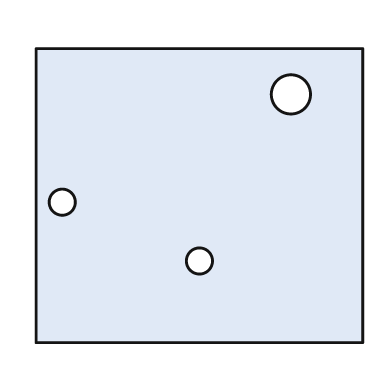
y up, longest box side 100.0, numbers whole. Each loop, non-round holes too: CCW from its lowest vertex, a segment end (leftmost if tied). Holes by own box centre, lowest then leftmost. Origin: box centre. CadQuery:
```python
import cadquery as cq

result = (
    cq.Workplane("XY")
    .moveTo(-50.0, -45.0)
    .lineTo(50.0, -45.0)
    .lineTo(50.0, 45.0)
    .lineTo(-50.0, 45.0)
    .close()
    .moveTo(0.0, -20.0)
    .circle(4.0)
    .moveTo(-42.0, -2.0)
    .circle(4.0)
    .moveTo(28.0, 31.0)
    .circle(6.0)
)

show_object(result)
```